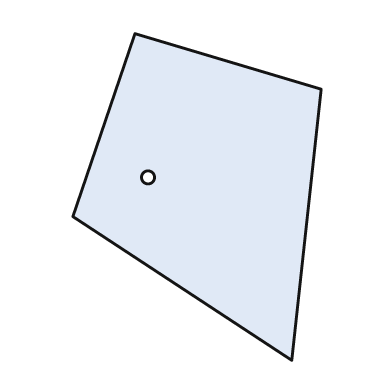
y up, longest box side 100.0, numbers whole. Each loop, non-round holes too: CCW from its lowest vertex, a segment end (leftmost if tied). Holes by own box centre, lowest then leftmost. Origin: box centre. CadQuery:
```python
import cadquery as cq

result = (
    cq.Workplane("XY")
    .moveTo(29.0, -50.0)
    .lineTo(38.0, 33.0)
    .lineTo(-19.0, 50.0)
    .lineTo(-38.0, -6.0)
    .close()
    .moveTo(-15.0, 6.0)
    .circle(2.0)
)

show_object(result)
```